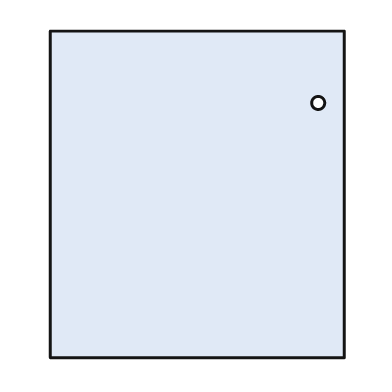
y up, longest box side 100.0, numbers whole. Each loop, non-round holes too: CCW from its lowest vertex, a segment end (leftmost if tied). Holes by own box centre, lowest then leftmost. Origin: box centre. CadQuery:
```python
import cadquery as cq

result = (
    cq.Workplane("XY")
    .moveTo(-45.0, -50.0)
    .lineTo(45.0, -50.0)
    .lineTo(45.0, 50.0)
    .lineTo(-45.0, 50.0)
    .close()
    .moveTo(37.0, 28.0)
    .circle(2.0)
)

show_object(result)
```